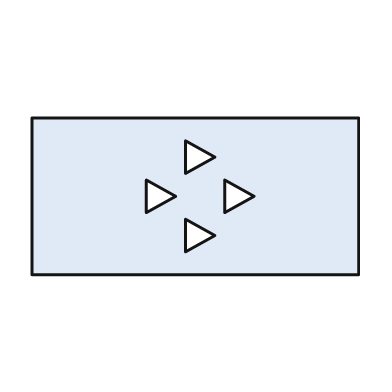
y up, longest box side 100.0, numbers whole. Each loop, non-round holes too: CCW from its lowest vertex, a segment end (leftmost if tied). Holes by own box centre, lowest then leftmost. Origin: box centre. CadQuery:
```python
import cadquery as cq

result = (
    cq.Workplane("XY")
    .moveTo(-50.0, -24.0)
    .lineTo(50.0, -24.0)
    .lineTo(50.0, 24.0)
    .lineTo(-50.0, 24.0)
    .close()
    .moveTo(-3.0, -17.0)
    .lineTo(6.0, -12.0)
    .lineTo(-3.0, -7.0)
    .close()
    .moveTo(-15.0, -5.0)
    .lineTo(-6.0, 0.0)
    .lineTo(-15.0, 5.0)
    .close()
    .moveTo(9.0, -5.0)
    .lineTo(18.0, 0.0)
    .lineTo(9.0, 5.0)
    .close()
    .moveTo(-3.0, 7.0)
    .lineTo(6.0, 12.0)
    .lineTo(-3.0, 17.0)
    .close()
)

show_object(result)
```